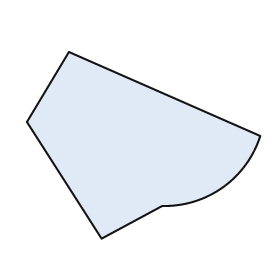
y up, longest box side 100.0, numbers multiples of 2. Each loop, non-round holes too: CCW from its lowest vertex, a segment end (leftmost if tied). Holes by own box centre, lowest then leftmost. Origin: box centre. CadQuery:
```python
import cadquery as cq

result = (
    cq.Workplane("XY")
    .moveTo(-18.0, -40.0)
    .lineTo(8.0, -26.0)
    .threePointArc((34.0, -18.0), (50.0, 4.0))
    .lineTo(-32.0, 40.0)
    .lineTo(-50.0, 10.0)
    .close()
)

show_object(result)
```